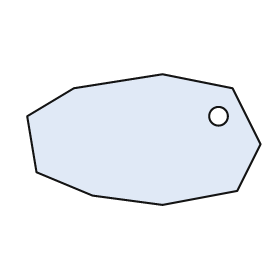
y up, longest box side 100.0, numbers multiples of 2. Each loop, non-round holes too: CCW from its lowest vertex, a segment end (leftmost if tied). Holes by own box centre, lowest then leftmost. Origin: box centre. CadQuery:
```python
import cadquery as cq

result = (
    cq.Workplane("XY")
    .moveTo(8.0, -28.0)
    .lineTo(40.0, -22.0)
    .lineTo(50.0, -2.0)
    .lineTo(38.0, 22.0)
    .lineTo(8.0, 28.0)
    .lineTo(-30.0, 22.0)
    .lineTo(-50.0, 10.0)
    .lineTo(-46.0, -14.0)
    .lineTo(-22.0, -24.0)
    .close()
    .moveTo(32.0, 10.0)
    .circle(4.0)
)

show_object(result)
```